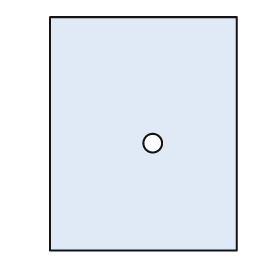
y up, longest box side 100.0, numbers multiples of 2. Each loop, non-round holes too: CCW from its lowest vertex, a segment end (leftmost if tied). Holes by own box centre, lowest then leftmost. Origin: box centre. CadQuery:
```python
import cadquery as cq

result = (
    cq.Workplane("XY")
    .moveTo(-40.0, -50.0)
    .lineTo(40.0, -50.0)
    .lineTo(40.0, 50.0)
    .lineTo(-40.0, 50.0)
    .close()
    .moveTo(4.0, -4.0)
    .circle(4.0)
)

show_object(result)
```